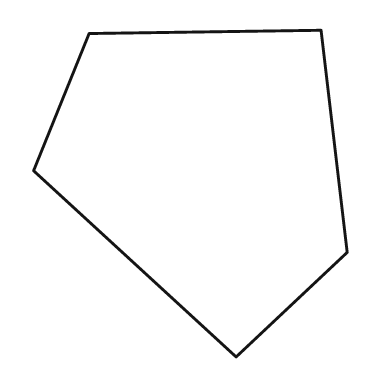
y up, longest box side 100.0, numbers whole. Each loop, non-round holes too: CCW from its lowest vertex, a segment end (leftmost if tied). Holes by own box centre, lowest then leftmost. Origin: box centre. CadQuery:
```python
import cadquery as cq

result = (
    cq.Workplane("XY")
    .moveTo(14.0, -50.0)
    .lineTo(48.0, -18.0)
    .lineTo(40.0, 50.0)
    .lineTo(-31.0, 49.0)
    .lineTo(-48.0, 7.0)
    .close()
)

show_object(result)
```